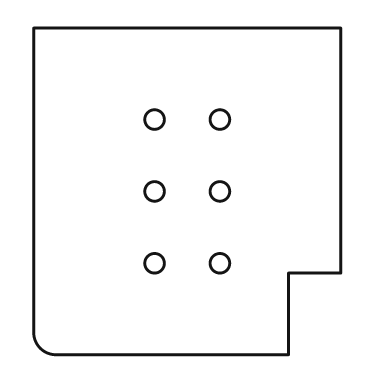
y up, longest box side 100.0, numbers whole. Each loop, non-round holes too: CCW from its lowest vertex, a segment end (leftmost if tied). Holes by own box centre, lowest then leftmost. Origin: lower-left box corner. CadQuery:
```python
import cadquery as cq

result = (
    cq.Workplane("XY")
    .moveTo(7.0, 0.0)
    .lineTo(78.0, 0.0)
    .lineTo(78.0, 25.0)
    .lineTo(94.0, 25.0)
    .lineTo(94.0, 100.0)
    .lineTo(0.0, 100.0)
    .lineTo(0.0, 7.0)
    .threePointArc((2.0, 2.0), (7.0, 0.0))
    .close()
    .moveTo(37.0, 28.0)
    .circle(3.0)
    .moveTo(57.0, 28.0)
    .circle(3.0)
    .moveTo(37.0, 50.0)
    .circle(3.0)
    .moveTo(57.0, 50.0)
    .circle(3.0)
    .moveTo(37.0, 72.0)
    .circle(3.0)
    .moveTo(57.0, 72.0)
    .circle(3.0)
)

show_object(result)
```